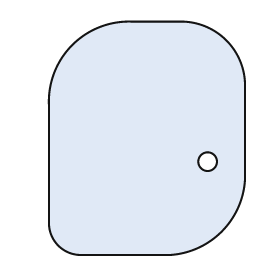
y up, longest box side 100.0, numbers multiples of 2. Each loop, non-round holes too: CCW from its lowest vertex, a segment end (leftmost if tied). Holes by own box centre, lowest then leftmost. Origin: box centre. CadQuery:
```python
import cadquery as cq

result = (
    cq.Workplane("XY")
    .moveTo(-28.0, -50.0)
    .lineTo(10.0, -50.0)
    .threePointArc((32.0, -40.0), (42.0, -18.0))
    .lineTo(42.0, 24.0)
    .threePointArc((34.0, 42.0), (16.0, 50.0))
    .lineTo(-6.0, 50.0)
    .threePointArc((-32.0, 40.0), (-42.0, 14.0))
    .lineTo(-42.0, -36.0)
    .threePointArc((-38.0, -46.0), (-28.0, -50.0))
    .close()
    .moveTo(26.0, -10.0)
    .circle(4.0)
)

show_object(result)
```